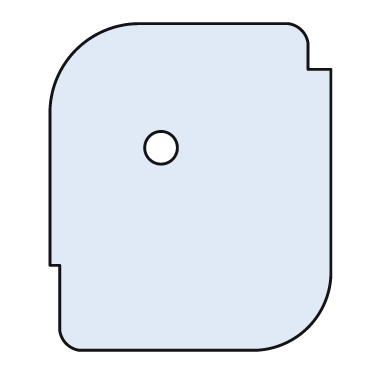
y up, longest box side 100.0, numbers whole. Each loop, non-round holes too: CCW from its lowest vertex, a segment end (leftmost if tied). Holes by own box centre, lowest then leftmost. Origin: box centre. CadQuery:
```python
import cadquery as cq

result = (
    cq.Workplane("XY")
    .moveTo(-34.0, -50.0)
    .lineTo(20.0, -50.0)
    .threePointArc((36.0, -43.0), (43.0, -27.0))
    .lineTo(43.0, 36.0)
    .lineTo(36.0, 36.0)
    .lineTo(36.0, 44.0)
    .threePointArc((34.0, 48.0), (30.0, 50.0))
    .lineTo(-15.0, 50.0)
    .threePointArc((-35.0, 42.0), (-43.0, 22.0))
    .lineTo(-43.0, -24.0)
    .lineTo(-40.0, -24.0)
    .lineTo(-40.0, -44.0)
    .threePointArc((-38.0, -48.0), (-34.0, -50.0))
    .close()
    .moveTo(-9.0, 12.0)
    .circle(5.0)
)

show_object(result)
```